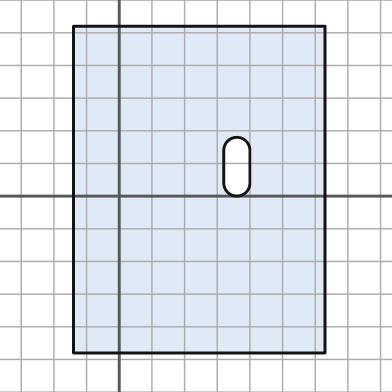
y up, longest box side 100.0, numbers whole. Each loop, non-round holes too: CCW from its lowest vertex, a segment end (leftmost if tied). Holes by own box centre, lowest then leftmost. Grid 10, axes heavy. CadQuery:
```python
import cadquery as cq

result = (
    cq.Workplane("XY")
    .moveTo(-14.0, -48.0)
    .lineTo(63.0, -48.0)
    .lineTo(63.0, 52.0)
    .lineTo(-14.0, 52.0)
    .close()
    .moveTo(32.0, 4.0)
    .threePointArc((36.0, 0.0), (40.0, 4.0))
    .lineTo(40.0, 14.0)
    .threePointArc((36.0, 18.0), (32.0, 14.0))
    .close()
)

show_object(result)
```